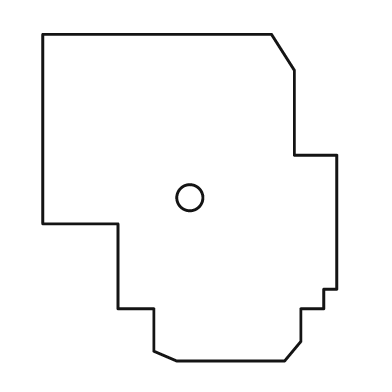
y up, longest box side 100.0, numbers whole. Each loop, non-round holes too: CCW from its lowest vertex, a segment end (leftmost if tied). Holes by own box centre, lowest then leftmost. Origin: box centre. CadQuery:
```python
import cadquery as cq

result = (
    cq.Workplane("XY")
    .moveTo(-4.0, -50.0)
    .lineTo(29.0, -50.0)
    .lineTo(34.0, -44.0)
    .lineTo(34.0, -34.0)
    .lineTo(41.0, -34.0)
    .lineTo(41.0, -28.0)
    .lineTo(45.0, -28.0)
    .lineTo(45.0, 13.0)
    .lineTo(32.0, 13.0)
    .lineTo(32.0, 39.0)
    .lineTo(25.0, 50.0)
    .lineTo(-45.0, 50.0)
    .lineTo(-45.0, -8.0)
    .lineTo(-22.0, -8.0)
    .lineTo(-22.0, -34.0)
    .lineTo(-11.0, -34.0)
    .lineTo(-11.0, -47.0)
    .close()
    .moveTo(0.0, 0.0)
    .circle(4.0)
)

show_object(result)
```